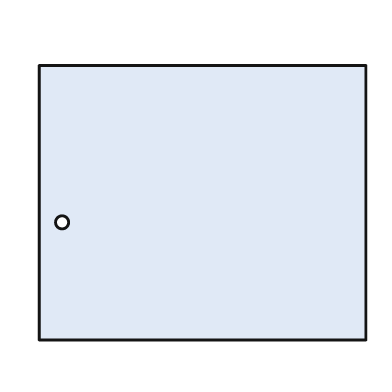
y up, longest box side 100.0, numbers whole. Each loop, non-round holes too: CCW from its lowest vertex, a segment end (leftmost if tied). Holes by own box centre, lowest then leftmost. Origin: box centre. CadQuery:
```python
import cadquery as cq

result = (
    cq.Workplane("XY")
    .moveTo(-50.0, -42.0)
    .lineTo(50.0, -42.0)
    .lineTo(50.0, 42.0)
    .lineTo(-50.0, 42.0)
    .close()
    .moveTo(-43.0, -6.0)
    .circle(2.0)
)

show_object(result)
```